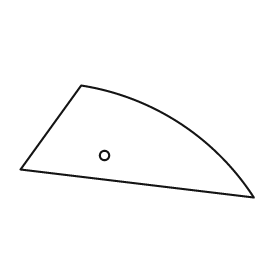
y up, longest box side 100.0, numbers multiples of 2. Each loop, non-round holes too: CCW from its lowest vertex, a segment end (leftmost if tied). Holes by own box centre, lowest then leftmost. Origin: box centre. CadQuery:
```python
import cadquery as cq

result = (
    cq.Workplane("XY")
    .moveTo(50.0, -24.0)
    .threePointArc((18.0, 8.0), (-24.0, 24.0))
    .lineTo(-50.0, -12.0)
    .close()
    .moveTo(-14.0, -6.0)
    .circle(2.0)
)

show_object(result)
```